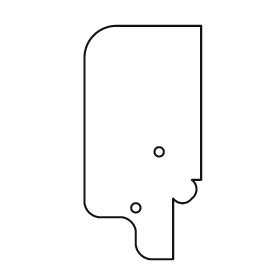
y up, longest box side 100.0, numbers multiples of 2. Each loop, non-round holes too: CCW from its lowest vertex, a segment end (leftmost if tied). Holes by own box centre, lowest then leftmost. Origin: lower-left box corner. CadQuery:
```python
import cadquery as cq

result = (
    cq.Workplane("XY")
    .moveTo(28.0, 0.0)
    .lineTo(38.0, 0.0)
    .lineTo(38.0, 26.0)
    .threePointArc((42.0, 24.0), (46.0, 26.0))
    .threePointArc((48.0, 30.0), (46.0, 34.0))
    .lineTo(50.0, 34.0)
    .lineTo(50.0, 100.0)
    .lineTo(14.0, 100.0)
    .threePointArc((4.0, 96.0), (0.0, 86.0))
    .lineTo(0.0, 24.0)
    .threePointArc((2.0, 20.0), (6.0, 18.0))
    .lineTo(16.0, 18.0)
    .threePointArc((20.0, 16.0), (22.0, 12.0))
    .lineTo(22.0, 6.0)
    .threePointArc((24.0, 2.0), (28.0, 0.0))
    .close()
    .moveTo(22.0, 22.0)
    .circle(2.0)
    .moveTo(32.0, 46.0)
    .circle(2.0)
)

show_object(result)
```